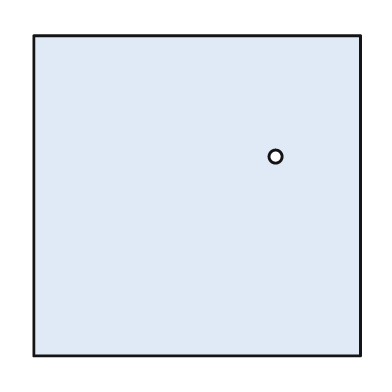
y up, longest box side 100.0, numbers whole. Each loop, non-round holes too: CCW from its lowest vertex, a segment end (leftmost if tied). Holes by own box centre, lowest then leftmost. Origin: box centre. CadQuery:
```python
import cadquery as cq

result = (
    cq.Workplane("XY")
    .moveTo(-50.0, -49.0)
    .lineTo(50.0, -49.0)
    .lineTo(50.0, 49.0)
    .lineTo(-50.0, 49.0)
    .close()
    .moveTo(24.0, 12.0)
    .circle(2.0)
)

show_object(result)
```